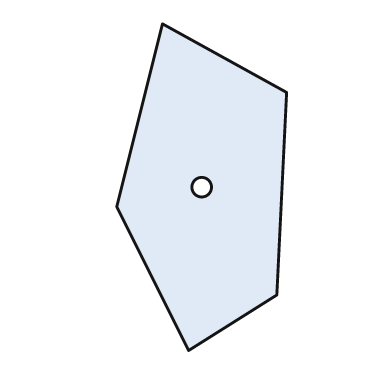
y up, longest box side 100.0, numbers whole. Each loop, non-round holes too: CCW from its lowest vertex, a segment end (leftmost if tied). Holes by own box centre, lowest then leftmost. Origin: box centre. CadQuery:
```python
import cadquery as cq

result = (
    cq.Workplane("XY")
    .moveTo(-4.0, -50.0)
    .lineTo(23.0, -33.0)
    .lineTo(26.0, 29.0)
    .lineTo(-12.0, 50.0)
    .lineTo(-26.0, -6.0)
    .close()
    .moveTo(0.0, 0.0)
    .circle(3.0)
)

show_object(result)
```